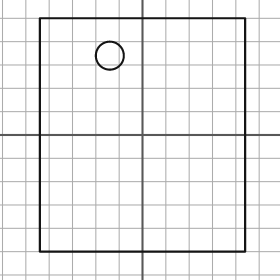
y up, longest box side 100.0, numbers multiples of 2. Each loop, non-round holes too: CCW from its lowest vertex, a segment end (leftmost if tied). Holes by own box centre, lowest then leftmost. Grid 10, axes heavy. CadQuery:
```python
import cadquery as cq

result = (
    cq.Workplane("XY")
    .moveTo(-44.0, -50.0)
    .lineTo(44.0, -50.0)
    .lineTo(44.0, 50.0)
    .lineTo(-44.0, 50.0)
    .close()
    .moveTo(-14.0, 34.0)
    .circle(6.0)
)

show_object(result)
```